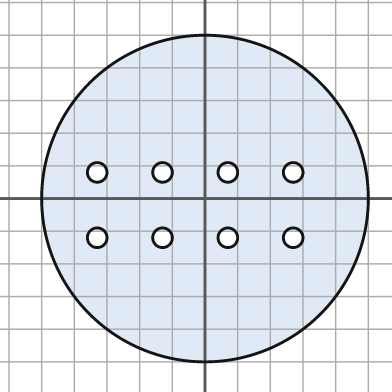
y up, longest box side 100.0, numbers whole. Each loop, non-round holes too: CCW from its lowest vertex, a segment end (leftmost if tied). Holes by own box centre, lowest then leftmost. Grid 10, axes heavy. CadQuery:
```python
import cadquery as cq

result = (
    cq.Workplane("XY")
    .moveTo(0.0, 0.0)
    .circle(50.0)
    .moveTo(-33.0, -12.0)
    .circle(3.0)
    .moveTo(-13.0, -12.0)
    .circle(3.0)
    .moveTo(7.0, -12.0)
    .circle(3.0)
    .moveTo(27.0, -12.0)
    .circle(3.0)
    .moveTo(-33.0, 8.0)
    .circle(3.0)
    .moveTo(-13.0, 8.0)
    .circle(3.0)
    .moveTo(7.0, 8.0)
    .circle(3.0)
    .moveTo(27.0, 8.0)
    .circle(3.0)
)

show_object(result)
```